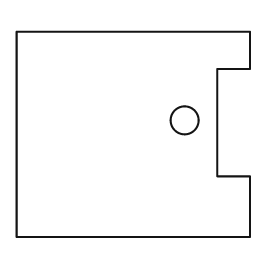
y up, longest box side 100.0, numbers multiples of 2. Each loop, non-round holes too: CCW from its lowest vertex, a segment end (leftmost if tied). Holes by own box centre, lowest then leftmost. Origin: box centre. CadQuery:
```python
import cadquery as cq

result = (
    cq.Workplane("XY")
    .moveTo(-50.0, -44.0)
    .lineTo(50.0, -44.0)
    .lineTo(50.0, -18.0)
    .lineTo(36.0, -18.0)
    .lineTo(36.0, 28.0)
    .lineTo(50.0, 28.0)
    .lineTo(50.0, 44.0)
    .lineTo(-50.0, 44.0)
    .close()
    .moveTo(22.0, 6.0)
    .circle(6.0)
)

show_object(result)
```